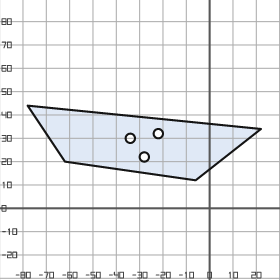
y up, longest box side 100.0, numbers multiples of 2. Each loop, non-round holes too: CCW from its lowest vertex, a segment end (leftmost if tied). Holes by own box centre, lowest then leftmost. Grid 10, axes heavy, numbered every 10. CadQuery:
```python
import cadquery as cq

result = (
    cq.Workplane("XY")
    .moveTo(-6.0, 12.0)
    .lineTo(22.0, 34.0)
    .lineTo(-78.0, 44.0)
    .lineTo(-62.0, 20.0)
    .close()
    .moveTo(-28.0, 22.0)
    .circle(2.0)
    .moveTo(-34.0, 30.0)
    .circle(2.0)
    .moveTo(-22.0, 32.0)
    .circle(2.0)
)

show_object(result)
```